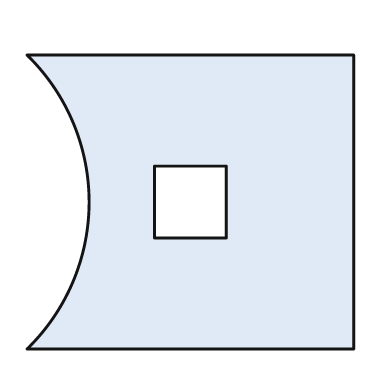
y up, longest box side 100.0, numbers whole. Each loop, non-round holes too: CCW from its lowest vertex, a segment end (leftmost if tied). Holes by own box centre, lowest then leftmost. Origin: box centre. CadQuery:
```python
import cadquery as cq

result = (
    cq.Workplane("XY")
    .moveTo(-50.0, -45.0)
    .lineTo(50.0, -45.0)
    .lineTo(50.0, 45.0)
    .lineTo(-50.0, 45.0)
    .threePointArc((-31.0, 0.0), (-50.0, -45.0))
    .close()
    .moveTo(-11.0, -11.0)
    .lineTo(11.0, -11.0)
    .lineTo(11.0, 11.0)
    .lineTo(-11.0, 11.0)
    .close()
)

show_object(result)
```